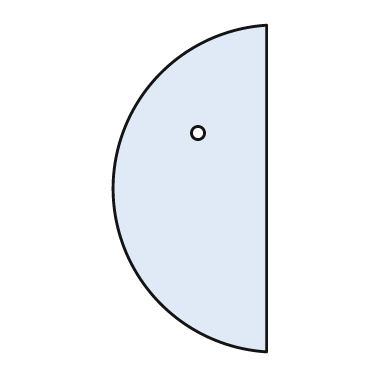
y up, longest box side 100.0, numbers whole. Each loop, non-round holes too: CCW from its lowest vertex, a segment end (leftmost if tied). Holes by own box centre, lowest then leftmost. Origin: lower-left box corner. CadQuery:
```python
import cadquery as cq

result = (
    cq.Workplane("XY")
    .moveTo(47.0, 0.0)
    .lineTo(47.0, 100.0)
    .threePointArc((0.0, 50.0), (47.0, 0.0))
    .close()
    .moveTo(26.0, 67.0)
    .circle(2.0)
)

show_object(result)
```